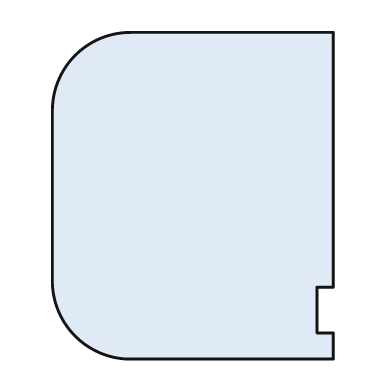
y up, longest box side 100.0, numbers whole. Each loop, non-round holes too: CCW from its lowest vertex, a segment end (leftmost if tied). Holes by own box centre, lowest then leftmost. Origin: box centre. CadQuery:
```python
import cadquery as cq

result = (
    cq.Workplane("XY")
    .moveTo(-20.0, -50.0)
    .lineTo(43.0, -50.0)
    .lineTo(43.0, -42.0)
    .lineTo(38.0, -42.0)
    .lineTo(38.0, -28.0)
    .lineTo(43.0, -28.0)
    .lineTo(43.0, 50.0)
    .lineTo(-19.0, 50.0)
    .threePointArc((-36.0, 43.0), (-43.0, 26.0))
    .lineTo(-43.0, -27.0)
    .threePointArc((-36.0, -43.0), (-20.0, -50.0))
    .close()
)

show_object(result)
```